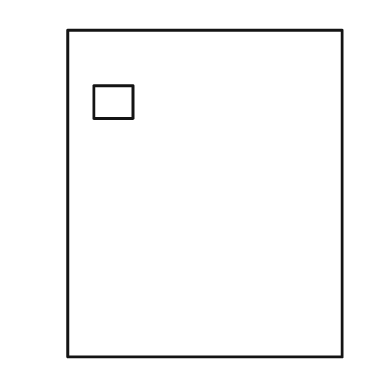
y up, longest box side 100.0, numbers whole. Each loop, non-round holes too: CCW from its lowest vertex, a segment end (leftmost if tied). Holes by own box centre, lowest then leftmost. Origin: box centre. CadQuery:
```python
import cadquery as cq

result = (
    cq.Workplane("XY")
    .moveTo(-42.0, -50.0)
    .lineTo(42.0, -50.0)
    .lineTo(42.0, 50.0)
    .lineTo(-42.0, 50.0)
    .close()
    .moveTo(-34.0, 23.0)
    .lineTo(-22.0, 23.0)
    .lineTo(-22.0, 33.0)
    .lineTo(-34.0, 33.0)
    .close()
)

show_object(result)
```